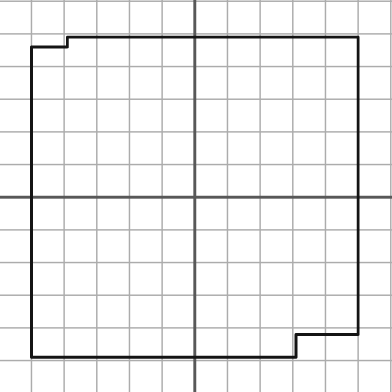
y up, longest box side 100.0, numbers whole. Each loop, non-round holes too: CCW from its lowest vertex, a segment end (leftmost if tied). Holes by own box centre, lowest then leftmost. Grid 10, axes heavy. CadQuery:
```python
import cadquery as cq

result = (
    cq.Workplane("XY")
    .moveTo(-50.0, -49.0)
    .lineTo(31.0, -49.0)
    .lineTo(31.0, -42.0)
    .lineTo(50.0, -42.0)
    .lineTo(50.0, 49.0)
    .lineTo(-39.0, 49.0)
    .lineTo(-39.0, 46.0)
    .lineTo(-50.0, 46.0)
    .close()
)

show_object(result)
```